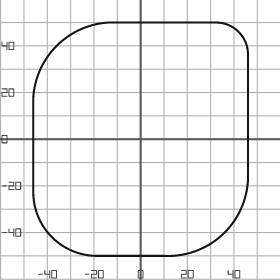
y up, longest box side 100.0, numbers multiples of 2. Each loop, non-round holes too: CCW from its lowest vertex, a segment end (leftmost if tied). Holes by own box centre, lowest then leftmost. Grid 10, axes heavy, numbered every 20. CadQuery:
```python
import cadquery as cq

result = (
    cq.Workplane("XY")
    .moveTo(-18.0, -50.0)
    .lineTo(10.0, -50.0)
    .threePointArc((36.0, -40.0), (46.0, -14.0))
    .lineTo(46.0, 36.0)
    .threePointArc((42.0, 46.0), (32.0, 50.0))
    .lineTo(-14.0, 50.0)
    .threePointArc((-36.0, 40.0), (-46.0, 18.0))
    .lineTo(-46.0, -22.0)
    .threePointArc((-38.0, -42.0), (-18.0, -50.0))
    .close()
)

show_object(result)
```